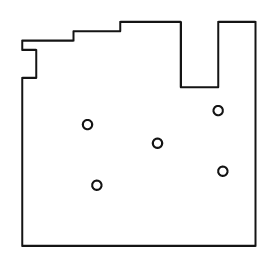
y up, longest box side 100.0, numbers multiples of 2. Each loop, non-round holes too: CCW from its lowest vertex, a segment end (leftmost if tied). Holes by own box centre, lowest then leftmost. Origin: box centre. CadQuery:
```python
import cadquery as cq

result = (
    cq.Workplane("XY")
    .moveTo(-50.0, -48.0)
    .lineTo(50.0, -48.0)
    .lineTo(50.0, 48.0)
    .lineTo(34.0, 48.0)
    .lineTo(34.0, 20.0)
    .lineTo(18.0, 20.0)
    .lineTo(18.0, 48.0)
    .lineTo(-8.0, 48.0)
    .lineTo(-8.0, 44.0)
    .lineTo(-28.0, 44.0)
    .lineTo(-28.0, 40.0)
    .lineTo(-50.0, 40.0)
    .lineTo(-50.0, 36.0)
    .lineTo(-44.0, 36.0)
    .lineTo(-44.0, 24.0)
    .lineTo(-50.0, 24.0)
    .close()
    .moveTo(-18.0, -22.0)
    .circle(2.0)
    .moveTo(36.0, -16.0)
    .circle(2.0)
    .moveTo(8.0, -4.0)
    .circle(2.0)
    .moveTo(-22.0, 4.0)
    .circle(2.0)
    .moveTo(34.0, 10.0)
    .circle(2.0)
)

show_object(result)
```